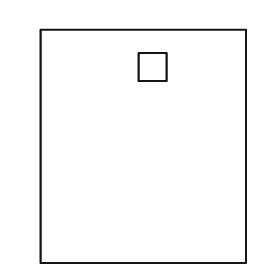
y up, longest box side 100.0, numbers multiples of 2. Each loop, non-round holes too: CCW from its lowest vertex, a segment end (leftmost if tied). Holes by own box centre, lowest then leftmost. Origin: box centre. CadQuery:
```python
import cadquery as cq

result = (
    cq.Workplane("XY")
    .moveTo(-44.0, -50.0)
    .lineTo(44.0, -50.0)
    .lineTo(44.0, 50.0)
    .lineTo(-44.0, 50.0)
    .close()
    .moveTo(-2.0, 28.0)
    .lineTo(10.0, 28.0)
    .lineTo(10.0, 40.0)
    .lineTo(-2.0, 40.0)
    .close()
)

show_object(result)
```